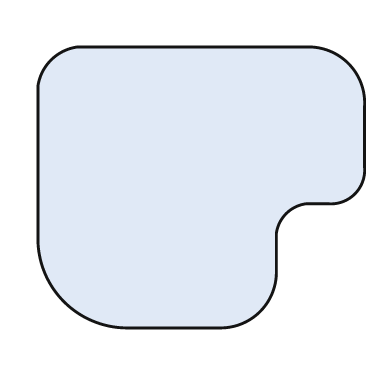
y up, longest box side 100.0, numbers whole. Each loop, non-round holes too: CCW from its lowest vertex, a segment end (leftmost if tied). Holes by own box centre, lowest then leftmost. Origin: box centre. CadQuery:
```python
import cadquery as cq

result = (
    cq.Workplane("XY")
    .moveTo(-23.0, -43.0)
    .lineTo(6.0, -43.0)
    .threePointArc((18.0, -38.0), (23.0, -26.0))
    .lineTo(23.0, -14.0)
    .threePointArc((26.0, -8.0), (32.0, -5.0))
    .lineTo(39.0, -5.0)
    .threePointArc((47.0, -2.0), (50.0, 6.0))
    .lineTo(50.0, 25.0)
    .threePointArc((45.0, 38.0), (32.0, 43.0))
    .lineTo(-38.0, 43.0)
    .threePointArc((-46.0, 39.0), (-50.0, 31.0))
    .lineTo(-50.0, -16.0)
    .threePointArc((-42.0, -35.0), (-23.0, -43.0))
    .close()
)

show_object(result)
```